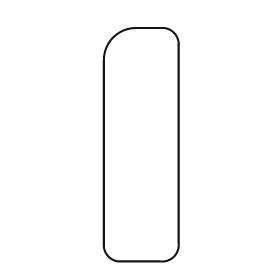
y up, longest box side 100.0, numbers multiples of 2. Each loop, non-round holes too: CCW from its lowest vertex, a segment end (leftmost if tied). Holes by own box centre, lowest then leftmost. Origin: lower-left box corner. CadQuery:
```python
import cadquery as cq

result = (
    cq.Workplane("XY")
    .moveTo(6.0, 0.0)
    .lineTo(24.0, 0.0)
    .threePointArc((30.0, 2.0), (32.0, 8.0))
    .lineTo(32.0, 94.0)
    .threePointArc((30.0, 98.0), (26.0, 100.0))
    .lineTo(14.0, 100.0)
    .threePointArc((4.0, 96.0), (0.0, 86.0))
    .lineTo(0.0, 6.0)
    .threePointArc((2.0, 2.0), (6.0, 0.0))
    .close()
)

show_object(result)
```